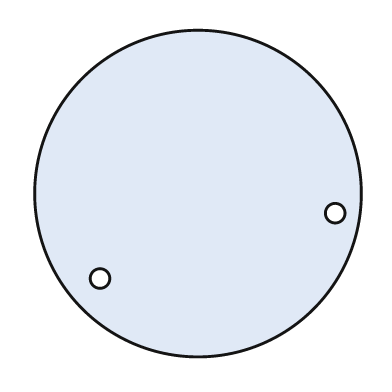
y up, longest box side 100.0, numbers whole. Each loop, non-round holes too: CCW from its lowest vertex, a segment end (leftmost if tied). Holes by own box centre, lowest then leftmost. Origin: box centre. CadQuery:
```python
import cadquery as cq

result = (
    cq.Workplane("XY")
    .moveTo(0.0, 0.0)
    .circle(50.0)
    .moveTo(-30.0, -26.0)
    .circle(3.0)
    .moveTo(42.0, -6.0)
    .circle(3.0)
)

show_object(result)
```